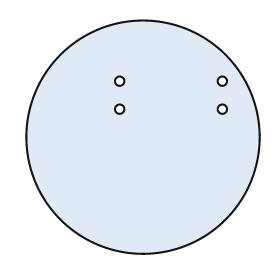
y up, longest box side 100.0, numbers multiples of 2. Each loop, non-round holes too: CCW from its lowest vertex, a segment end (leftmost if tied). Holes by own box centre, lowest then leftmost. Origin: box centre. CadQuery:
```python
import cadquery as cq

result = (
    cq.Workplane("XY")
    .moveTo(0.0, 0.0)
    .circle(50.0)
    .moveTo(-10.0, 12.0)
    .circle(2.0)
    .moveTo(34.0, 12.0)
    .circle(2.0)
    .moveTo(-10.0, 24.0)
    .circle(2.0)
    .moveTo(34.0, 24.0)
    .circle(2.0)
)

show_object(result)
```